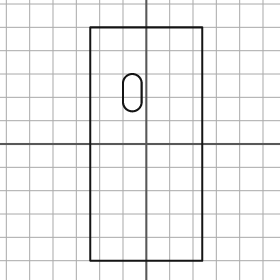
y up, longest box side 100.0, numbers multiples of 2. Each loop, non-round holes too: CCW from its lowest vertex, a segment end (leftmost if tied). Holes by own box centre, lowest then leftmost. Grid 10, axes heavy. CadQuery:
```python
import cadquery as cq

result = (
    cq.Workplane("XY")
    .moveTo(-24.0, -50.0)
    .lineTo(24.0, -50.0)
    .lineTo(24.0, 50.0)
    .lineTo(-24.0, 50.0)
    .close()
    .moveTo(-10.0, 18.0)
    .threePointArc((-6.0, 14.0), (-2.0, 18.0))
    .lineTo(-2.0, 26.0)
    .threePointArc((-6.0, 30.0), (-10.0, 26.0))
    .close()
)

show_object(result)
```